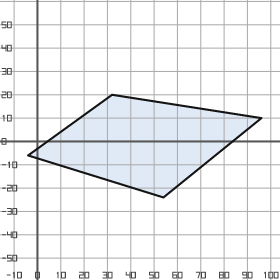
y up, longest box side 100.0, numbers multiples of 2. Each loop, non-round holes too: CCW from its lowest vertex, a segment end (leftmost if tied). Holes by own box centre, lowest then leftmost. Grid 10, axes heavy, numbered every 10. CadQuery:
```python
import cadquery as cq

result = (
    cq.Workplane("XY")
    .moveTo(54.0, -24.0)
    .lineTo(96.0, 10.0)
    .lineTo(32.0, 20.0)
    .lineTo(-4.0, -6.0)
    .close()
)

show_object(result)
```